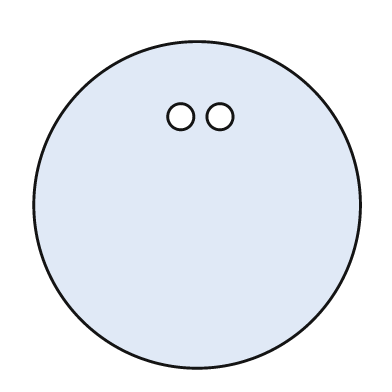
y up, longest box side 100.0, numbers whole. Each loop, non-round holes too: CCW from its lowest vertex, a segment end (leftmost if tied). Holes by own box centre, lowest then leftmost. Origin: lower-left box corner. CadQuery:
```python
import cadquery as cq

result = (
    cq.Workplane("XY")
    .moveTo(50.0, 50.0)
    .circle(50.0)
    .moveTo(45.0, 77.0)
    .circle(4.0)
    .moveTo(57.0, 77.0)
    .circle(4.0)
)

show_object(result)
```